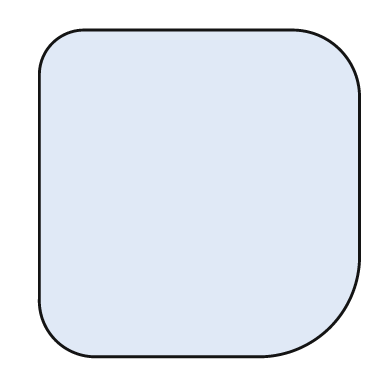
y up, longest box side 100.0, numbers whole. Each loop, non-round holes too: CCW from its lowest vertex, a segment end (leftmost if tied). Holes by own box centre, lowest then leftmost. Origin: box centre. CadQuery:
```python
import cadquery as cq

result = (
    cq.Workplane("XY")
    .moveTo(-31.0, -50.0)
    .lineTo(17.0, -50.0)
    .threePointArc((40.0, -41.0), (49.0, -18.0))
    .lineTo(49.0, 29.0)
    .threePointArc((43.0, 44.0), (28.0, 50.0))
    .lineTo(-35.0, 50.0)
    .threePointArc((-45.0, 46.0), (-49.0, 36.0))
    .lineTo(-49.0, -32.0)
    .threePointArc((-44.0, -45.0), (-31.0, -50.0))
    .close()
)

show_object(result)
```